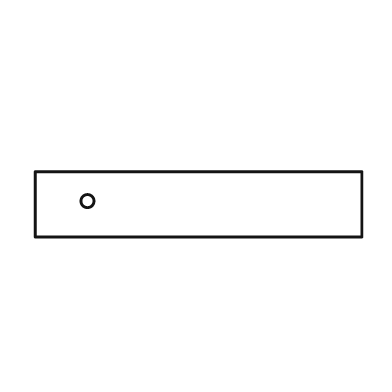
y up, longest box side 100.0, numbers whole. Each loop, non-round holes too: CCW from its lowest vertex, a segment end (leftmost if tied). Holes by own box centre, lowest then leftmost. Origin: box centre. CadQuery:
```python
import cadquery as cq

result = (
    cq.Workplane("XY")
    .moveTo(-50.0, -10.0)
    .lineTo(50.0, -10.0)
    .lineTo(50.0, 10.0)
    .lineTo(-50.0, 10.0)
    .close()
    .moveTo(-34.0, 1.0)
    .circle(2.0)
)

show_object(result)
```